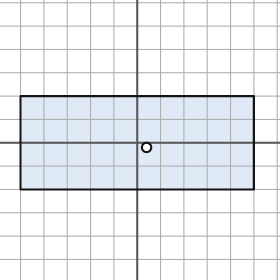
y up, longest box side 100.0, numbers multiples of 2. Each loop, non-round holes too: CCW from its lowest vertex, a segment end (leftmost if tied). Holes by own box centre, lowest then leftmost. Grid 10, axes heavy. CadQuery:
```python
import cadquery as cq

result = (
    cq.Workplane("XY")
    .moveTo(-50.0, -20.0)
    .lineTo(50.0, -20.0)
    .lineTo(50.0, 20.0)
    .lineTo(-50.0, 20.0)
    .close()
    .moveTo(4.0, -2.0)
    .circle(2.0)
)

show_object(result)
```